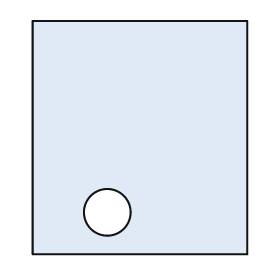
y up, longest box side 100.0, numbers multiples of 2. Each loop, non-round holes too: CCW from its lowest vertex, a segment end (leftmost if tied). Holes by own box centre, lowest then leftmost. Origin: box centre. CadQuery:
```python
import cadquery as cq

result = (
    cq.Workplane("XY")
    .moveTo(-46.0, -50.0)
    .lineTo(46.0, -50.0)
    .lineTo(46.0, 50.0)
    .lineTo(-46.0, 50.0)
    .close()
    .moveTo(-14.0, -32.0)
    .circle(10.0)
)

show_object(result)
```